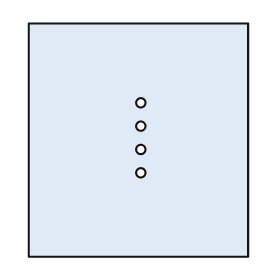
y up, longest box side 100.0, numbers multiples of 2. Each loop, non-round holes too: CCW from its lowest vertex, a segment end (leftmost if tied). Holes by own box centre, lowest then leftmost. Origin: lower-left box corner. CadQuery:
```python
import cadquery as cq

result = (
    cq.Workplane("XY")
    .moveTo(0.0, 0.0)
    .lineTo(94.0, 0.0)
    .lineTo(94.0, 100.0)
    .lineTo(0.0, 100.0)
    .close()
    .moveTo(48.0, 36.0)
    .circle(2.0)
    .moveTo(48.0, 46.0)
    .circle(2.0)
    .moveTo(48.0, 56.0)
    .circle(2.0)
    .moveTo(48.0, 66.0)
    .circle(2.0)
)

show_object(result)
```